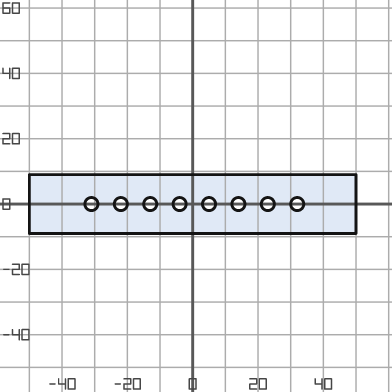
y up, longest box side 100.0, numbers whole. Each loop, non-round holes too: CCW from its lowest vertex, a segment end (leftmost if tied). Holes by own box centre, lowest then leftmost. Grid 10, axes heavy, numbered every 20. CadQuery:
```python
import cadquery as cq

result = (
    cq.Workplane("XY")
    .moveTo(-50.0, -9.0)
    .lineTo(50.0, -9.0)
    .lineTo(50.0, 9.0)
    .lineTo(-50.0, 9.0)
    .close()
    .moveTo(-31.0, 0.0)
    .circle(2.0)
    .moveTo(-22.0, 0.0)
    .circle(2.0)
    .moveTo(-13.0, 0.0)
    .circle(2.0)
    .moveTo(-4.0, 0.0)
    .circle(2.0)
    .moveTo(5.0, 0.0)
    .circle(2.0)
    .moveTo(14.0, 0.0)
    .circle(2.0)
    .moveTo(23.0, 0.0)
    .circle(2.0)
    .moveTo(32.0, 0.0)
    .circle(2.0)
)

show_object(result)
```